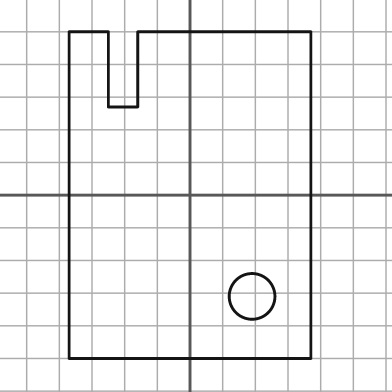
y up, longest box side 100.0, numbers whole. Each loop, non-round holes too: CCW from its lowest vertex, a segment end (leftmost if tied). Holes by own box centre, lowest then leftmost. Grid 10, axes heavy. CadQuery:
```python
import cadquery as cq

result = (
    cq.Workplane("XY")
    .moveTo(-37.0, -50.0)
    .lineTo(37.0, -50.0)
    .lineTo(37.0, 50.0)
    .lineTo(-16.0, 50.0)
    .lineTo(-16.0, 27.0)
    .lineTo(-25.0, 27.0)
    .lineTo(-25.0, 50.0)
    .lineTo(-37.0, 50.0)
    .close()
    .moveTo(19.0, -31.0)
    .circle(7.0)
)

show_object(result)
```